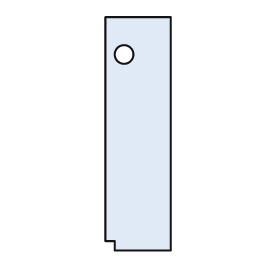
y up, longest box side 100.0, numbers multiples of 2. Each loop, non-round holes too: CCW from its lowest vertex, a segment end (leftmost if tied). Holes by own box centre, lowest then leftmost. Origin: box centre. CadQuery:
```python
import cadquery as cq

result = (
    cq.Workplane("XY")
    .moveTo(-10.0, -50.0)
    .lineTo(14.0, -50.0)
    .lineTo(14.0, 50.0)
    .lineTo(-14.0, 50.0)
    .lineTo(-14.0, -46.0)
    .lineTo(-10.0, -46.0)
    .close()
    .moveTo(-6.0, 34.0)
    .circle(4.0)
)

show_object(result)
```